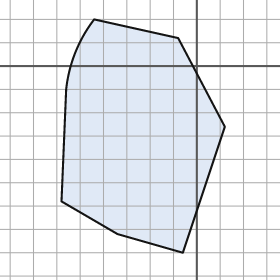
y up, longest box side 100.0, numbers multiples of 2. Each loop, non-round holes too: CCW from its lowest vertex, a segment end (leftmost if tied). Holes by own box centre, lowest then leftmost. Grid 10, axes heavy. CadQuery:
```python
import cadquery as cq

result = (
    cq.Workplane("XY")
    .moveTo(-6.0, -80.0)
    .lineTo(12.0, -26.0)
    .lineTo(-8.0, 12.0)
    .lineTo(-44.0, 20.0)
    .threePointArc((-52.0, 6.0), (-56.0, -10.0))
    .lineTo(-58.0, -58.0)
    .lineTo(-34.0, -72.0)
    .close()
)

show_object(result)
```